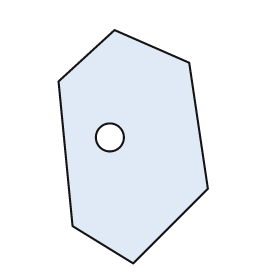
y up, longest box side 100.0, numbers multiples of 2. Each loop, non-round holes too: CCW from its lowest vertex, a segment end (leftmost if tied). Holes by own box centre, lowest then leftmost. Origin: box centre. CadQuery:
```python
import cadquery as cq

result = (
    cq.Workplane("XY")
    .moveTo(0.0, -50.0)
    .lineTo(32.0, -18.0)
    .lineTo(24.0, 36.0)
    .lineTo(-8.0, 50.0)
    .lineTo(-32.0, 28.0)
    .lineTo(-26.0, -34.0)
    .close()
    .moveTo(-10.0, 4.0)
    .circle(6.0)
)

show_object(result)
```